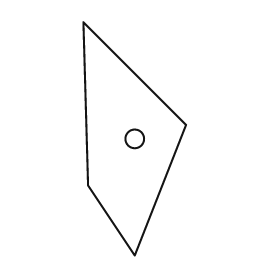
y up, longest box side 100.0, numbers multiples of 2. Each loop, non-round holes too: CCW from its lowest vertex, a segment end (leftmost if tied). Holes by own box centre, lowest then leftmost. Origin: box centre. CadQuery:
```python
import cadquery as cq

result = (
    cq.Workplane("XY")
    .moveTo(0.0, -50.0)
    .lineTo(22.0, 6.0)
    .lineTo(-22.0, 50.0)
    .lineTo(-20.0, -20.0)
    .close()
    .moveTo(0.0, 0.0)
    .circle(4.0)
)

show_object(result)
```